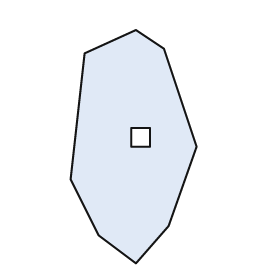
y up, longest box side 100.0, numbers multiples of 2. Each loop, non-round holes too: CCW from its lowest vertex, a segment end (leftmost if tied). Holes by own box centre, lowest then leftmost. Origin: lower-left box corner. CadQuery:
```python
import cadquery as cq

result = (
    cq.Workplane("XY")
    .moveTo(28.0, 0.0)
    .lineTo(42.0, 16.0)
    .lineTo(54.0, 50.0)
    .lineTo(40.0, 92.0)
    .lineTo(28.0, 100.0)
    .lineTo(6.0, 90.0)
    .lineTo(0.0, 36.0)
    .lineTo(12.0, 12.0)
    .close()
    .moveTo(26.0, 50.0)
    .lineTo(34.0, 50.0)
    .lineTo(34.0, 58.0)
    .lineTo(26.0, 58.0)
    .close()
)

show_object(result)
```